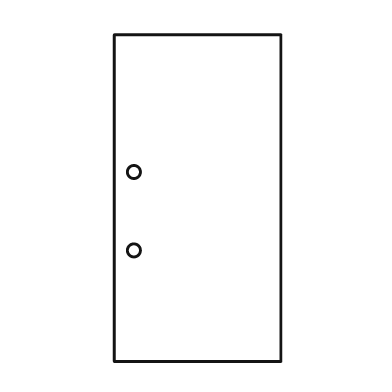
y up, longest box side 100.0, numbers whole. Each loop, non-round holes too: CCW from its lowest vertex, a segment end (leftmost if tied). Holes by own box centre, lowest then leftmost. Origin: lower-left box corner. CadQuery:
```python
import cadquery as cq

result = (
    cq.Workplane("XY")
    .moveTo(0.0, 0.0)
    .lineTo(51.0, 0.0)
    .lineTo(51.0, 100.0)
    .lineTo(0.0, 100.0)
    .close()
    .moveTo(6.0, 34.0)
    .circle(2.0)
    .moveTo(6.0, 58.0)
    .circle(2.0)
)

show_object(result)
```